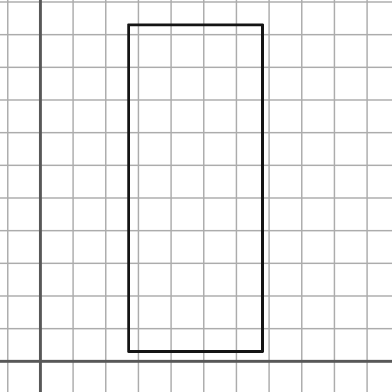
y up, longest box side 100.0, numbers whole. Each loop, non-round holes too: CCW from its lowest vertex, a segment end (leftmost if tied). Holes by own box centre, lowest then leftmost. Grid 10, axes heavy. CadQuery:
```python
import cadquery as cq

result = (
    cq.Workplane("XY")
    .moveTo(27.0, 3.0)
    .lineTo(68.0, 3.0)
    .lineTo(68.0, 103.0)
    .lineTo(27.0, 103.0)
    .close()
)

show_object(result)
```